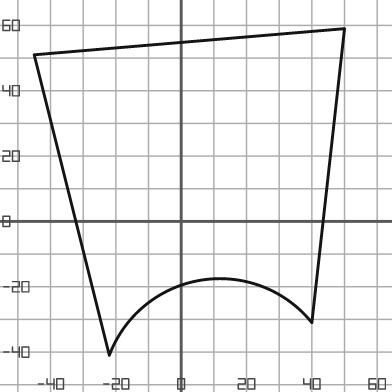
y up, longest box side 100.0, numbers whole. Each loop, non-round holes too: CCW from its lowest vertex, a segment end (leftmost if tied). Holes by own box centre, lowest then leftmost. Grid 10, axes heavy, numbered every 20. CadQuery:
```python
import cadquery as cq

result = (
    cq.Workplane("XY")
    .moveTo(-22.0, -41.0)
    .threePointArc((6.0, -18.0), (40.0, -31.0))
    .lineTo(50.0, 59.0)
    .lineTo(-45.0, 51.0)
    .close()
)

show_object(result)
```